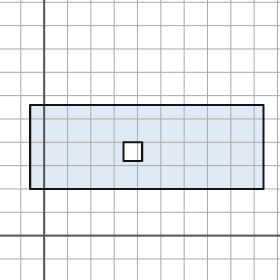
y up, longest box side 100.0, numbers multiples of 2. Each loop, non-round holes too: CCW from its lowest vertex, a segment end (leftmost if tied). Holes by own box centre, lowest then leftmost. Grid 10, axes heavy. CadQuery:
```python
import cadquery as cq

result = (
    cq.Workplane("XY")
    .moveTo(-6.0, 20.0)
    .lineTo(94.0, 20.0)
    .lineTo(94.0, 56.0)
    .lineTo(-6.0, 56.0)
    .close()
    .moveTo(34.0, 32.0)
    .lineTo(42.0, 32.0)
    .lineTo(42.0, 40.0)
    .lineTo(34.0, 40.0)
    .close()
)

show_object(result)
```